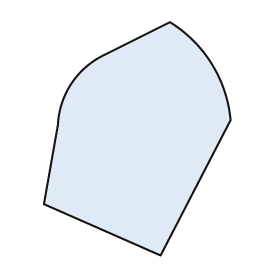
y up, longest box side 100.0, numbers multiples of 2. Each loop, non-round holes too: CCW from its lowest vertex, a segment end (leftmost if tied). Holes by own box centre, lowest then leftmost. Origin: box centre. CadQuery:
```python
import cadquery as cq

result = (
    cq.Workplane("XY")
    .moveTo(10.0, -50.0)
    .lineTo(40.0, 8.0)
    .threePointArc((32.0, 32.0), (14.0, 50.0))
    .lineTo(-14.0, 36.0)
    .threePointArc((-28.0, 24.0), (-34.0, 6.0))
    .lineTo(-40.0, -28.0)
    .close()
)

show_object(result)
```